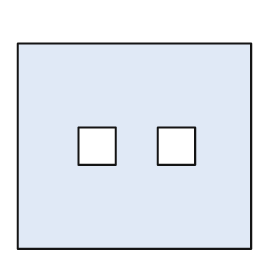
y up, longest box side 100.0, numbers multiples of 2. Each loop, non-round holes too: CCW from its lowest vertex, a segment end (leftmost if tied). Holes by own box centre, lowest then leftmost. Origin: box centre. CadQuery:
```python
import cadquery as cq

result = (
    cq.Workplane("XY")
    .moveTo(-50.0, -44.0)
    .lineTo(50.0, -44.0)
    .lineTo(50.0, 44.0)
    .lineTo(-50.0, 44.0)
    .close()
    .moveTo(-24.0, -8.0)
    .lineTo(-8.0, -8.0)
    .lineTo(-8.0, 8.0)
    .lineTo(-24.0, 8.0)
    .close()
    .moveTo(10.0, -8.0)
    .lineTo(26.0, -8.0)
    .lineTo(26.0, 8.0)
    .lineTo(10.0, 8.0)
    .close()
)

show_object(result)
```